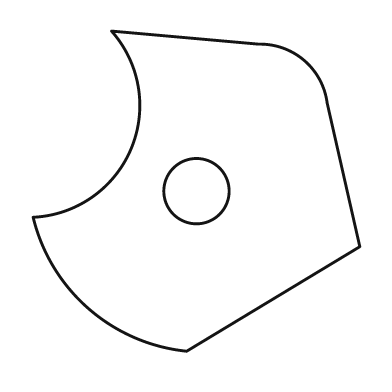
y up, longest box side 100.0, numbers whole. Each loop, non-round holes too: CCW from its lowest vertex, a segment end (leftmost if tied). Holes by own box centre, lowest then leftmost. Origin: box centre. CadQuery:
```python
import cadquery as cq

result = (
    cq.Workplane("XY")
    .moveTo(-3.0, -49.0)
    .lineTo(50.0, -17.0)
    .lineTo(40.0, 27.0)
    .threePointArc((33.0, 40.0), (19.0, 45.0))
    .lineTo(-26.0, 49.0)
    .threePointArc((-20.0, 13.0), (-50.0, -8.0))
    .threePointArc((-33.0, -36.0), (-3.0, -49.0))
    .close()
    .moveTo(0.0, 0.0)
    .circle(10.0)
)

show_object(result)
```